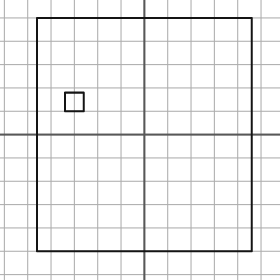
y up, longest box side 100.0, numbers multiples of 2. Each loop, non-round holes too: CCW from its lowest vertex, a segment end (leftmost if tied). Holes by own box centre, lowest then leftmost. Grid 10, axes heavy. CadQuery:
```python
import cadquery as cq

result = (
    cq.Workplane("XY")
    .moveTo(-46.0, -50.0)
    .lineTo(46.0, -50.0)
    .lineTo(46.0, 50.0)
    .lineTo(-46.0, 50.0)
    .close()
    .moveTo(-34.0, 10.0)
    .lineTo(-26.0, 10.0)
    .lineTo(-26.0, 18.0)
    .lineTo(-34.0, 18.0)
    .close()
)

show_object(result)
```